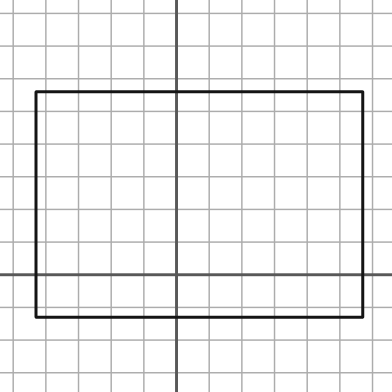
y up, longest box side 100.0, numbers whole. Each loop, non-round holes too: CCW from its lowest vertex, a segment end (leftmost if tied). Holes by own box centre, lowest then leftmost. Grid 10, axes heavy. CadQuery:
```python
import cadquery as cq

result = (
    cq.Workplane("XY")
    .moveTo(-43.0, -13.0)
    .lineTo(57.0, -13.0)
    .lineTo(57.0, 56.0)
    .lineTo(-43.0, 56.0)
    .close()
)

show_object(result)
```